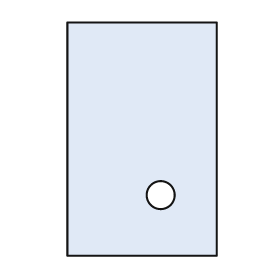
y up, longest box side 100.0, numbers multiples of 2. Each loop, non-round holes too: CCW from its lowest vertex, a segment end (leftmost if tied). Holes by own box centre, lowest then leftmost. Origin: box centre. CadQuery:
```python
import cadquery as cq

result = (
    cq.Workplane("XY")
    .moveTo(-32.0, -50.0)
    .lineTo(32.0, -50.0)
    .lineTo(32.0, 50.0)
    .lineTo(-32.0, 50.0)
    .close()
    .moveTo(8.0, -24.0)
    .circle(6.0)
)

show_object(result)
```